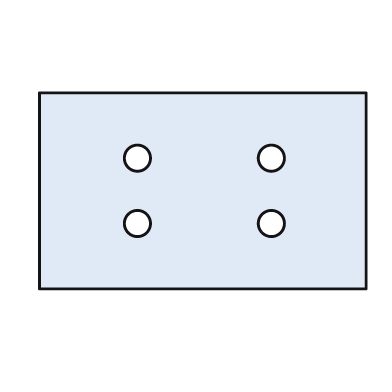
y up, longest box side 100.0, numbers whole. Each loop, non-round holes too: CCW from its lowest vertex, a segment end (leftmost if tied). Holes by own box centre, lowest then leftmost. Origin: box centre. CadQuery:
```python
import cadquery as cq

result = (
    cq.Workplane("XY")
    .moveTo(-50.0, -30.0)
    .lineTo(50.0, -30.0)
    .lineTo(50.0, 30.0)
    .lineTo(-50.0, 30.0)
    .close()
    .moveTo(-20.0, -10.0)
    .circle(4.0)
    .moveTo(21.0, -10.0)
    .circle(4.0)
    .moveTo(-20.0, 10.0)
    .circle(4.0)
    .moveTo(21.0, 10.0)
    .circle(4.0)
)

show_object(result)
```